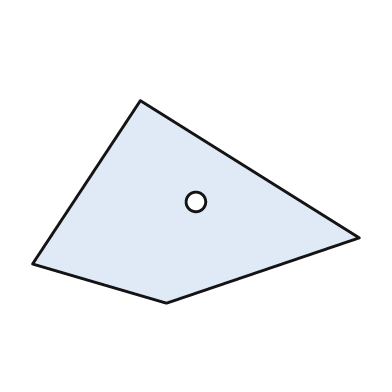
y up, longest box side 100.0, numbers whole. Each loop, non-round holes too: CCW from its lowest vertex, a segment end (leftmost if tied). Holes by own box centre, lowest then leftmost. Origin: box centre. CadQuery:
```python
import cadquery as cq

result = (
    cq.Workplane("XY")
    .moveTo(-9.0, -31.0)
    .lineTo(50.0, -11.0)
    .lineTo(-17.0, 31.0)
    .lineTo(-50.0, -19.0)
    .close()
    .moveTo(0.0, 0.0)
    .circle(3.0)
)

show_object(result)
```